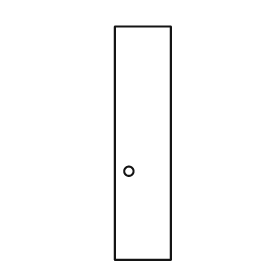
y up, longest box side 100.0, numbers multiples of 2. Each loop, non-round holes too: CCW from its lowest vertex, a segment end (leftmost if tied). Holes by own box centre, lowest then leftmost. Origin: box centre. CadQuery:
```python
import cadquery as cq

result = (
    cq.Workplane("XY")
    .moveTo(-12.0, -50.0)
    .lineTo(12.0, -50.0)
    .lineTo(12.0, 50.0)
    .lineTo(-12.0, 50.0)
    .close()
    .moveTo(-6.0, -12.0)
    .circle(2.0)
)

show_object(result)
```